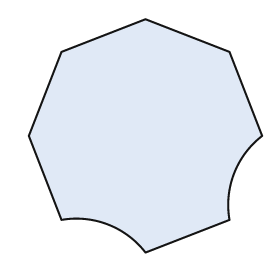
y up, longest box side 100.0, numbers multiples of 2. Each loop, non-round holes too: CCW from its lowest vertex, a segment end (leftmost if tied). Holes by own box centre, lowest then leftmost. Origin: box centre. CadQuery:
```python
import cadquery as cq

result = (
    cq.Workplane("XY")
    .moveTo(0.0, -50.0)
    .lineTo(36.0, -36.0)
    .threePointArc((38.0, -16.0), (50.0, 0.0))
    .lineTo(36.0, 36.0)
    .lineTo(0.0, 50.0)
    .lineTo(-36.0, 36.0)
    .lineTo(-50.0, 0.0)
    .lineTo(-36.0, -36.0)
    .threePointArc((-16.0, -38.0), (0.0, -50.0))
    .close()
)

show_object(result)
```